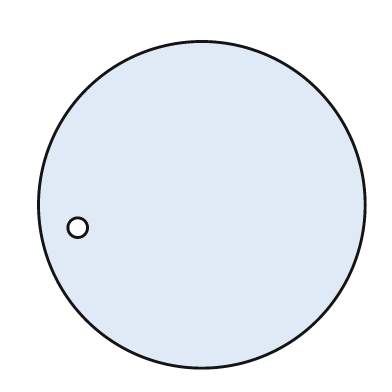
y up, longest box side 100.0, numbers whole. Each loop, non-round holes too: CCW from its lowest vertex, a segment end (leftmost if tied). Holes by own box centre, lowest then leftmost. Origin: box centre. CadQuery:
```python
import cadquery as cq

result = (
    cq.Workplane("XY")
    .moveTo(0.0, 0.0)
    .circle(50.0)
    .moveTo(-38.0, -7.0)
    .circle(3.0)
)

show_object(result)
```